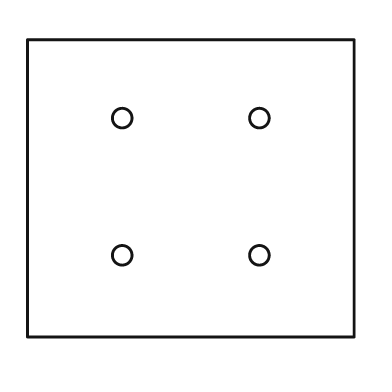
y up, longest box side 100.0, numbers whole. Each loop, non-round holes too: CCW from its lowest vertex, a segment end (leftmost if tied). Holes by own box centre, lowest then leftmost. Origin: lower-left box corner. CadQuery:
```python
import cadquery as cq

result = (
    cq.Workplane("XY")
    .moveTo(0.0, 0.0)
    .lineTo(100.0, 0.0)
    .lineTo(100.0, 91.0)
    .lineTo(0.0, 91.0)
    .close()
    .moveTo(29.0, 25.0)
    .circle(3.0)
    .moveTo(71.0, 25.0)
    .circle(3.0)
    .moveTo(29.0, 67.0)
    .circle(3.0)
    .moveTo(71.0, 67.0)
    .circle(3.0)
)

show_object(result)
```